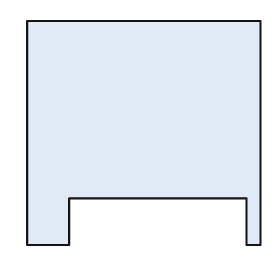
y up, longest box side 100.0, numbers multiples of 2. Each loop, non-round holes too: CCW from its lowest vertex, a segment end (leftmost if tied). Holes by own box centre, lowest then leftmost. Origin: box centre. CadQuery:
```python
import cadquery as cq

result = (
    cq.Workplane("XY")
    .moveTo(-50.0, -48.0)
    .lineTo(-32.0, -48.0)
    .lineTo(-32.0, -28.0)
    .lineTo(44.0, -28.0)
    .lineTo(44.0, -48.0)
    .lineTo(50.0, -48.0)
    .lineTo(50.0, 48.0)
    .lineTo(-50.0, 48.0)
    .close()
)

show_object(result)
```